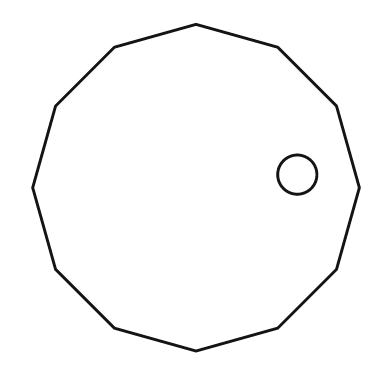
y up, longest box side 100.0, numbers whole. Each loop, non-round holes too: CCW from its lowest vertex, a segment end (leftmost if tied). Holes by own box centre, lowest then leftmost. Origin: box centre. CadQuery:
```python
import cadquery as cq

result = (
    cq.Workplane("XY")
    .moveTo(0.0, -50.0)
    .lineTo(25.0, -43.0)
    .lineTo(43.0, -25.0)
    .lineTo(50.0, 0.0)
    .lineTo(43.0, 25.0)
    .lineTo(25.0, 43.0)
    .lineTo(0.0, 50.0)
    .lineTo(-25.0, 43.0)
    .lineTo(-43.0, 25.0)
    .lineTo(-50.0, 0.0)
    .lineTo(-43.0, -25.0)
    .lineTo(-25.0, -43.0)
    .close()
    .moveTo(31.0, 4.0)
    .circle(6.0)
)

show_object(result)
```